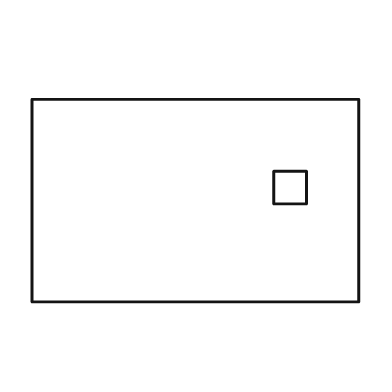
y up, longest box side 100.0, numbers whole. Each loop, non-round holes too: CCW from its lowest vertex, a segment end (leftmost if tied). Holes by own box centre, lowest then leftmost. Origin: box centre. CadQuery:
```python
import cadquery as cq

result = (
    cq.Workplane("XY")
    .moveTo(-50.0, -31.0)
    .lineTo(50.0, -31.0)
    .lineTo(50.0, 31.0)
    .lineTo(-50.0, 31.0)
    .close()
    .moveTo(24.0, -1.0)
    .lineTo(34.0, -1.0)
    .lineTo(34.0, 9.0)
    .lineTo(24.0, 9.0)
    .close()
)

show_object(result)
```